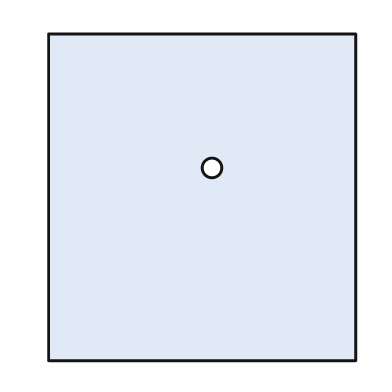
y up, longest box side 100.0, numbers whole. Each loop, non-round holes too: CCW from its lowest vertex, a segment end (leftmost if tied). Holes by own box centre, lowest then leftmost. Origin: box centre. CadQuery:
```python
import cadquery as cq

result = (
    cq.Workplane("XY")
    .moveTo(-47.0, -50.0)
    .lineTo(47.0, -50.0)
    .lineTo(47.0, 50.0)
    .lineTo(-47.0, 50.0)
    .close()
    .moveTo(3.0, 9.0)
    .circle(3.0)
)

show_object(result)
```